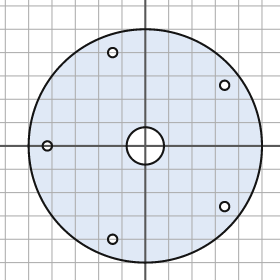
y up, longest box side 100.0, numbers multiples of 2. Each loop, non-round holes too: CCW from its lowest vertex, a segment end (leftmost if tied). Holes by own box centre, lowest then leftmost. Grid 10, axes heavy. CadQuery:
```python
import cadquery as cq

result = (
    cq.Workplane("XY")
    .moveTo(0.0, 0.0)
    .circle(50.0)
    .moveTo(-14.0, -40.0)
    .circle(2.0)
    .moveTo(34.0, -26.0)
    .circle(2.0)
    .moveTo(-42.0, 0.0)
    .circle(2.0)
    .moveTo(0.0, 0.0)
    .circle(8.0)
    .moveTo(34.0, 26.0)
    .circle(2.0)
    .moveTo(-14.0, 40.0)
    .circle(2.0)
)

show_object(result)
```